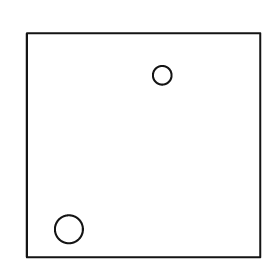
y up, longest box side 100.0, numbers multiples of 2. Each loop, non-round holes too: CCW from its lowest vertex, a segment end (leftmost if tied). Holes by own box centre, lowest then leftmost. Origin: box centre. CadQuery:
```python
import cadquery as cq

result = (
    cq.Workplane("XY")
    .moveTo(-50.0, -48.0)
    .lineTo(50.0, -48.0)
    .lineTo(50.0, 48.0)
    .lineTo(-50.0, 48.0)
    .close()
    .moveTo(-32.0, -36.0)
    .circle(6.0)
    .moveTo(8.0, 30.0)
    .circle(4.0)
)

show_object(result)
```